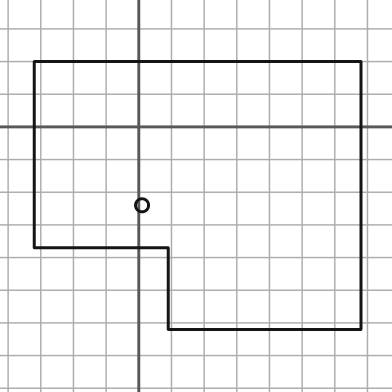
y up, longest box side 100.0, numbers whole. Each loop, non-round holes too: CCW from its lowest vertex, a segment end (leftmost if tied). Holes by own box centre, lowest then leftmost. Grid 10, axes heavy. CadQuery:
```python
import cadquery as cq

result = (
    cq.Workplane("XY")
    .moveTo(9.0, -62.0)
    .lineTo(68.0, -62.0)
    .lineTo(68.0, 20.0)
    .lineTo(-32.0, 20.0)
    .lineTo(-32.0, -37.0)
    .lineTo(9.0, -37.0)
    .close()
    .moveTo(1.0, -24.0)
    .circle(2.0)
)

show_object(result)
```